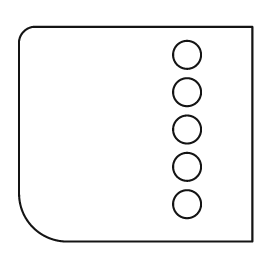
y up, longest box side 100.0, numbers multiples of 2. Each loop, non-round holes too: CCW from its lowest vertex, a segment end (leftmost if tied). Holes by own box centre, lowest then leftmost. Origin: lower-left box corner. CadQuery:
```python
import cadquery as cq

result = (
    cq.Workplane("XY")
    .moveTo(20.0, 0.0)
    .lineTo(100.0, 0.0)
    .lineTo(100.0, 92.0)
    .lineTo(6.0, 92.0)
    .threePointArc((2.0, 90.0), (0.0, 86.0))
    .lineTo(0.0, 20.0)
    .threePointArc((6.0, 6.0), (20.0, 0.0))
    .close()
    .moveTo(72.0, 16.0)
    .circle(6.0)
    .moveTo(72.0, 32.0)
    .circle(6.0)
    .moveTo(72.0, 48.0)
    .circle(6.0)
    .moveTo(72.0, 64.0)
    .circle(6.0)
    .moveTo(72.0, 80.0)
    .circle(6.0)
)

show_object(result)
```